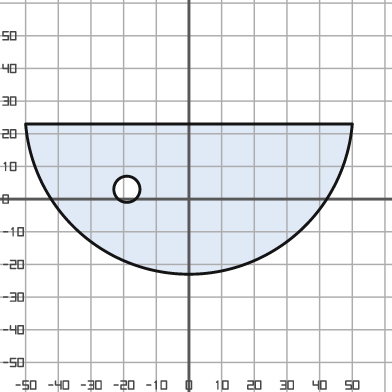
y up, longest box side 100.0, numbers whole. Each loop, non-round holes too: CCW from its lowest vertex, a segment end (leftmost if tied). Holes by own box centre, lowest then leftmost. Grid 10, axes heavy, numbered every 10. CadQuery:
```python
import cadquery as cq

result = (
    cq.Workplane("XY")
    .moveTo(-50.0, 23.0)
    .threePointArc((0.0, -23.0), (50.0, 23.0))
    .close()
    .moveTo(-19.0, 3.0)
    .circle(4.0)
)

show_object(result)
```